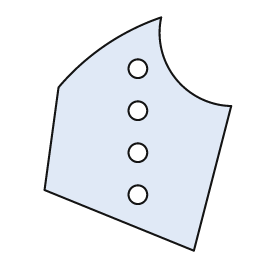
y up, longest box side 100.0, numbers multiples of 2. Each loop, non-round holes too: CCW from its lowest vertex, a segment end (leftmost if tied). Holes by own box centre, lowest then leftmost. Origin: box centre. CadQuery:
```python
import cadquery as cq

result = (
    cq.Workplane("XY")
    .moveTo(24.0, -50.0)
    .lineTo(40.0, 12.0)
    .threePointArc((16.0, 24.0), (10.0, 50.0))
    .threePointArc((-14.0, 38.0), (-34.0, 20.0))
    .lineTo(-40.0, -24.0)
    .close()
    .moveTo(0.0, -26.0)
    .circle(4.0)
    .moveTo(0.0, -8.0)
    .circle(4.0)
    .moveTo(0.0, 10.0)
    .circle(4.0)
    .moveTo(0.0, 28.0)
    .circle(4.0)
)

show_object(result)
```